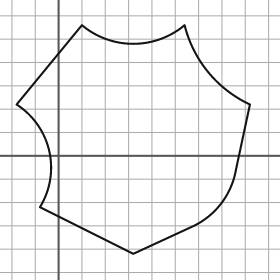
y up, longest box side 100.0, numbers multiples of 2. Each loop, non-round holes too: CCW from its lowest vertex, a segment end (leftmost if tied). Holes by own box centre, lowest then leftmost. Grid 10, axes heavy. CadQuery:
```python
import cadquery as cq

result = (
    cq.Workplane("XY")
    .moveTo(32.0, -42.0)
    .lineTo(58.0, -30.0)
    .threePointArc((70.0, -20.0), (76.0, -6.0))
    .lineTo(82.0, 22.0)
    .threePointArc((64.0, 36.0), (54.0, 56.0))
    .threePointArc((32.0, 48.0), (10.0, 56.0))
    .lineTo(-18.0, 22.0)
    .threePointArc((-4.0, 2.0), (-8.0, -22.0))
    .close()
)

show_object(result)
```